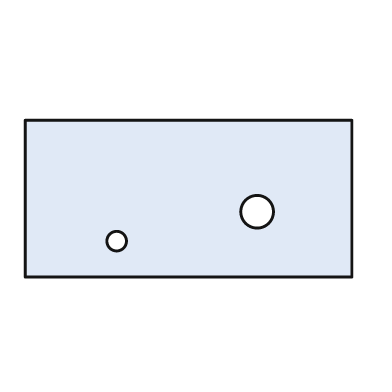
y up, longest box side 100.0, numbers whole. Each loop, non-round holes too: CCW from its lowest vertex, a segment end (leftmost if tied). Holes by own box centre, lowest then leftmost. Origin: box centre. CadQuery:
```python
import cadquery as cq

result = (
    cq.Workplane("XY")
    .moveTo(-50.0, -24.0)
    .lineTo(50.0, -24.0)
    .lineTo(50.0, 24.0)
    .lineTo(-50.0, 24.0)
    .close()
    .moveTo(-22.0, -13.0)
    .circle(3.0)
    .moveTo(21.0, -4.0)
    .circle(5.0)
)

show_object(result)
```